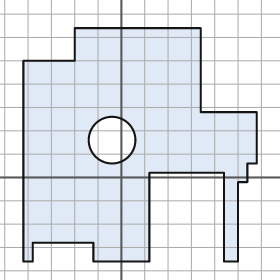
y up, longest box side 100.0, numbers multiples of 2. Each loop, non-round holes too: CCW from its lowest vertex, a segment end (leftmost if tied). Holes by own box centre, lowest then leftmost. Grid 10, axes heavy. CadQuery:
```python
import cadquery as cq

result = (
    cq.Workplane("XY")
    .moveTo(-42.0, -36.0)
    .lineTo(-38.0, -36.0)
    .lineTo(-38.0, -28.0)
    .lineTo(-12.0, -28.0)
    .lineTo(-12.0, -36.0)
    .lineTo(12.0, -36.0)
    .lineTo(12.0, 2.0)
    .lineTo(44.0, 2.0)
    .lineTo(44.0, -36.0)
    .lineTo(50.0, -36.0)
    .lineTo(50.0, -2.0)
    .lineTo(54.0, -2.0)
    .lineTo(54.0, 6.0)
    .lineTo(58.0, 6.0)
    .lineTo(58.0, 28.0)
    .lineTo(34.0, 28.0)
    .lineTo(34.0, 64.0)
    .lineTo(-20.0, 64.0)
    .lineTo(-20.0, 50.0)
    .lineTo(-42.0, 50.0)
    .close()
    .moveTo(-4.0, 16.0)
    .circle(10.0)
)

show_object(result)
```